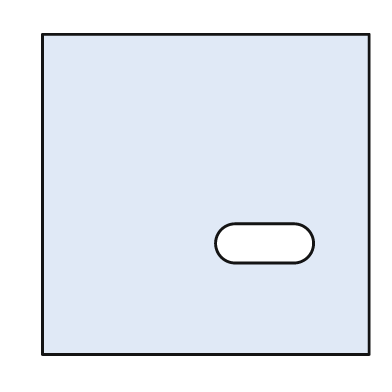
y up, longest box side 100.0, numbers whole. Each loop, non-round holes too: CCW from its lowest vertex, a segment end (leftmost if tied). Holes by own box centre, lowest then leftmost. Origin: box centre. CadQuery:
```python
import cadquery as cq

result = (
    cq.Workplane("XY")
    .moveTo(-50.0, -49.0)
    .lineTo(50.0, -49.0)
    .lineTo(50.0, 49.0)
    .lineTo(-50.0, 49.0)
    .close()
    .moveTo(9.0, -21.0)
    .lineTo(27.0, -21.0)
    .threePointArc((33.0, -15.0), (27.0, -9.0))
    .lineTo(9.0, -9.0)
    .threePointArc((3.0, -15.0), (9.0, -21.0))
    .close()
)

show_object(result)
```